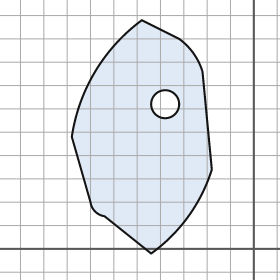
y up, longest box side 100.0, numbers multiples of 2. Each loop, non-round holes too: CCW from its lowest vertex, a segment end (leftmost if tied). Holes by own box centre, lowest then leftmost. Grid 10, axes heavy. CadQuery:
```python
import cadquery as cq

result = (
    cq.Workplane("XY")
    .moveTo(-44.0, -2.0)
    .threePointArc((-28.0, 14.0), (-18.0, 34.0))
    .lineTo(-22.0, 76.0)
    .threePointArc((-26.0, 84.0), (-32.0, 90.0))
    .lineTo(-48.0, 98.0)
    .threePointArc((-68.0, 76.0), (-78.0, 48.0))
    .lineTo(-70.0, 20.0)
    .threePointArc((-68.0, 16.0), (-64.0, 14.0))
    .close()
    .moveTo(-38.0, 62.0)
    .circle(6.0)
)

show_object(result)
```